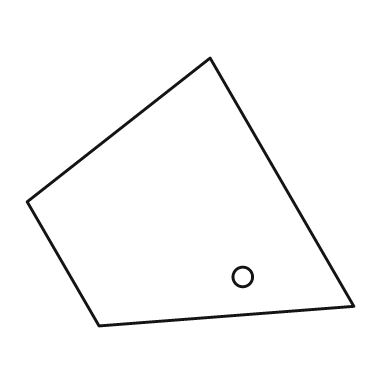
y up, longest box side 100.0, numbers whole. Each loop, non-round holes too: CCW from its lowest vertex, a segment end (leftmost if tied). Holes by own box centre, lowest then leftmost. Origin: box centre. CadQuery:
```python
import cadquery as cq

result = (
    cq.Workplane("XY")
    .moveTo(-28.0, -41.0)
    .lineTo(50.0, -35.0)
    .lineTo(6.0, 41.0)
    .lineTo(-50.0, -3.0)
    .close()
    .moveTo(16.0, -26.0)
    .circle(3.0)
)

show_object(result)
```